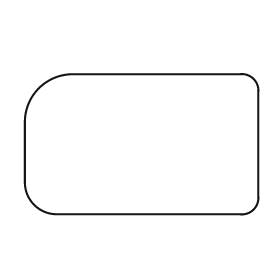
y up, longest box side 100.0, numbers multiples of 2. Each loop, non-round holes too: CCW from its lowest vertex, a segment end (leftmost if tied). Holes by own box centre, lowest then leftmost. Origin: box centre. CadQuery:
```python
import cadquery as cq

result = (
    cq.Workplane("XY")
    .moveTo(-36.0, -30.0)
    .lineTo(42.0, -30.0)
    .threePointArc((48.0, -28.0), (50.0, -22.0))
    .lineTo(50.0, 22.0)
    .threePointArc((48.0, 28.0), (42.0, 30.0))
    .lineTo(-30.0, 30.0)
    .threePointArc((-44.0, 24.0), (-50.0, 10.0))
    .lineTo(-50.0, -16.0)
    .threePointArc((-46.0, -26.0), (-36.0, -30.0))
    .close()
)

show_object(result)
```